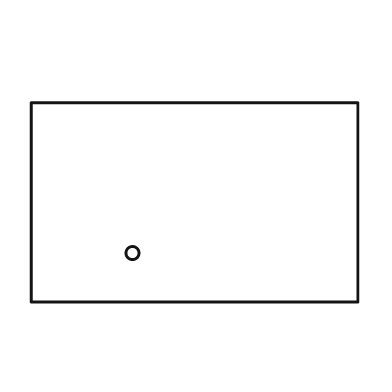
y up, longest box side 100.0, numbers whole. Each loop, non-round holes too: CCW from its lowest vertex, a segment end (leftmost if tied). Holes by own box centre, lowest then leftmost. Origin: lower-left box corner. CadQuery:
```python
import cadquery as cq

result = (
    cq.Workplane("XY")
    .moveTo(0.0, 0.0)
    .lineTo(100.0, 0.0)
    .lineTo(100.0, 61.0)
    .lineTo(0.0, 61.0)
    .close()
    .moveTo(31.0, 15.0)
    .circle(2.0)
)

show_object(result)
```